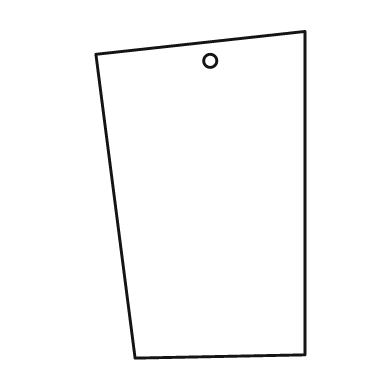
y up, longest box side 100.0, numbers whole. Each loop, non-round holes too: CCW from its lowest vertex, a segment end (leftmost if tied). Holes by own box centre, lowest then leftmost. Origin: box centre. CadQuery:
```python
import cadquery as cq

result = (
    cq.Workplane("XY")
    .moveTo(-20.0, -50.0)
    .lineTo(32.0, -49.0)
    .lineTo(32.0, 50.0)
    .lineTo(-32.0, 43.0)
    .close()
    .moveTo(3.0, 41.0)
    .circle(2.0)
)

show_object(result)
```